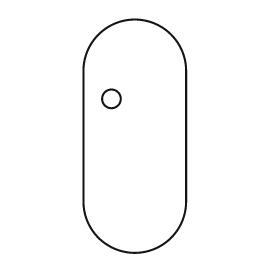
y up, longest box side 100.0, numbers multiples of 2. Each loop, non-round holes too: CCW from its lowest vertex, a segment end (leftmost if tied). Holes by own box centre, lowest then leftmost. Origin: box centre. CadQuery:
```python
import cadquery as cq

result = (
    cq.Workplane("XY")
    .moveTo(-22.0, -28.0)
    .threePointArc((0.0, -50.0), (22.0, -28.0))
    .lineTo(22.0, 28.0)
    .threePointArc((0.0, 50.0), (-22.0, 28.0))
    .close()
    .moveTo(-10.0, 16.0)
    .circle(4.0)
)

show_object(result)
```